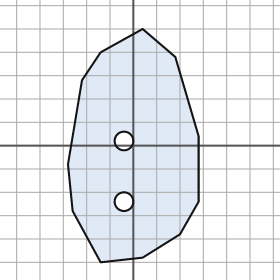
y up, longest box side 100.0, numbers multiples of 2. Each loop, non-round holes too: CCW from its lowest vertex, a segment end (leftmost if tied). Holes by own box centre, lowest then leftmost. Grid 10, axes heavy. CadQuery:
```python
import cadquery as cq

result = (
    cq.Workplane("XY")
    .moveTo(-14.0, -50.0)
    .lineTo(4.0, -48.0)
    .lineTo(20.0, -38.0)
    .lineTo(28.0, -24.0)
    .lineTo(28.0, 4.0)
    .lineTo(18.0, 38.0)
    .lineTo(4.0, 50.0)
    .lineTo(-14.0, 40.0)
    .lineTo(-22.0, 28.0)
    .lineTo(-28.0, -8.0)
    .lineTo(-26.0, -28.0)
    .close()
    .moveTo(-4.0, -24.0)
    .circle(4.0)
    .moveTo(-4.0, 2.0)
    .circle(4.0)
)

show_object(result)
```